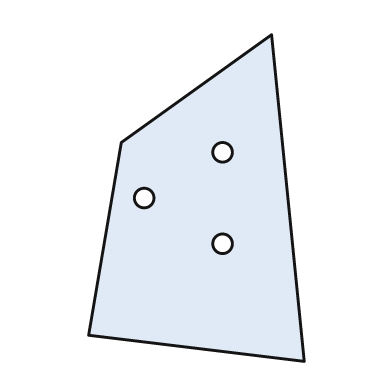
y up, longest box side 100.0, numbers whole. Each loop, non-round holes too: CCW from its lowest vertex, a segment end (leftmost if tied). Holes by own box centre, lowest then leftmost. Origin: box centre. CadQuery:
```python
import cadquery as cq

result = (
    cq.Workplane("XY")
    .moveTo(33.0, -50.0)
    .lineTo(23.0, 50.0)
    .lineTo(-23.0, 17.0)
    .lineTo(-33.0, -42.0)
    .close()
    .moveTo(8.0, -14.0)
    .circle(3.0)
    .moveTo(-16.0, 0.0)
    .circle(3.0)
    .moveTo(8.0, 14.0)
    .circle(3.0)
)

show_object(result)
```